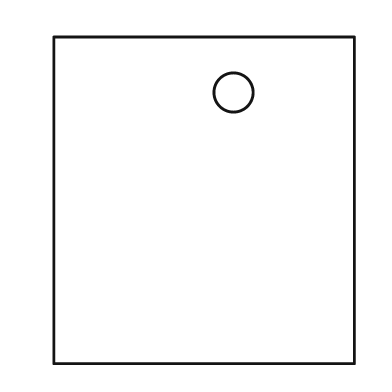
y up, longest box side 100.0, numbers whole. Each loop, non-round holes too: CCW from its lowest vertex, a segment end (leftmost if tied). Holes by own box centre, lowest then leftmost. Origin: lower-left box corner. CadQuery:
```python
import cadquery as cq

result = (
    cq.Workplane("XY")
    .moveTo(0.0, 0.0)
    .lineTo(92.0, 0.0)
    .lineTo(92.0, 100.0)
    .lineTo(0.0, 100.0)
    .close()
    .moveTo(55.0, 83.0)
    .circle(6.0)
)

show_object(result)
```